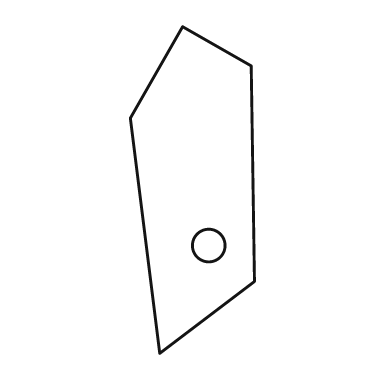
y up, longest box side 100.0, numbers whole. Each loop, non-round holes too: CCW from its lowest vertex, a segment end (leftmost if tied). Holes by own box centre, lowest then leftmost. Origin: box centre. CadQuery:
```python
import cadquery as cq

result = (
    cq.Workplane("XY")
    .moveTo(-10.0, -50.0)
    .lineTo(19.0, -28.0)
    .lineTo(18.0, 38.0)
    .lineTo(-3.0, 50.0)
    .lineTo(-19.0, 22.0)
    .close()
    .moveTo(5.0, -17.0)
    .circle(5.0)
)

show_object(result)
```